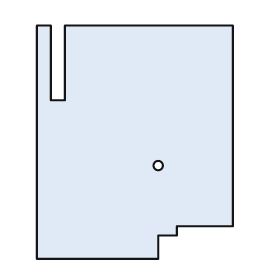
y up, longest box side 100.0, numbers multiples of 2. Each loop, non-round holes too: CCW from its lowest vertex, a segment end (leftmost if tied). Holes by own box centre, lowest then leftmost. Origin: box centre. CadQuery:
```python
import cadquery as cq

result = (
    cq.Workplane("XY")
    .moveTo(-42.0, -50.0)
    .lineTo(10.0, -50.0)
    .lineTo(10.0, -40.0)
    .lineTo(18.0, -40.0)
    .lineTo(18.0, -36.0)
    .lineTo(42.0, -36.0)
    .lineTo(42.0, 50.0)
    .lineTo(-30.0, 50.0)
    .lineTo(-30.0, 18.0)
    .lineTo(-36.0, 18.0)
    .lineTo(-36.0, 50.0)
    .lineTo(-42.0, 50.0)
    .close()
    .moveTo(10.0, -10.0)
    .circle(2.0)
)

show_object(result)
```